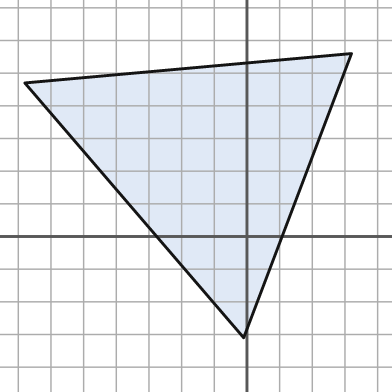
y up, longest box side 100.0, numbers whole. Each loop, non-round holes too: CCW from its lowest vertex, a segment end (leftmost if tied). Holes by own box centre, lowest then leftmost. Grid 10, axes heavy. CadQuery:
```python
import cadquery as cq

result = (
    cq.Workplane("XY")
    .moveTo(-1.0, -31.0)
    .lineTo(32.0, 56.0)
    .lineTo(-68.0, 47.0)
    .close()
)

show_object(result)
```